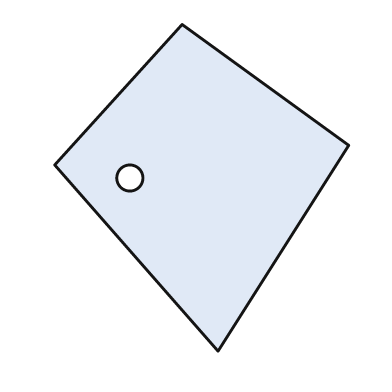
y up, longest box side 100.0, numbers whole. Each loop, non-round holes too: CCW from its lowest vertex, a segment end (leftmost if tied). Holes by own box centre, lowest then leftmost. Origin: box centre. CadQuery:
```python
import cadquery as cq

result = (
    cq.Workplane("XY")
    .moveTo(5.0, -50.0)
    .lineTo(45.0, 13.0)
    .lineTo(-6.0, 50.0)
    .lineTo(-45.0, 7.0)
    .close()
    .moveTo(-22.0, 3.0)
    .circle(4.0)
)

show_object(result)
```